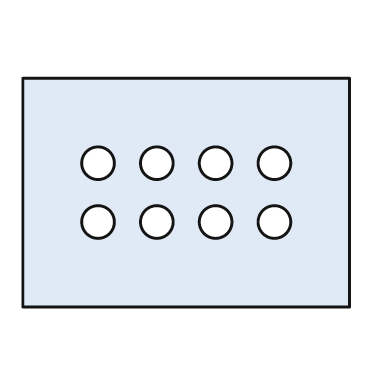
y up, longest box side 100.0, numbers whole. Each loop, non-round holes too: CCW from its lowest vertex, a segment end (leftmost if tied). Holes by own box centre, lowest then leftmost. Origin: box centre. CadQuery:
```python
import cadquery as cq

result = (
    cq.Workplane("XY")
    .moveTo(-50.0, -35.0)
    .lineTo(50.0, -35.0)
    .lineTo(50.0, 35.0)
    .lineTo(-50.0, 35.0)
    .close()
    .moveTo(-27.0, -9.0)
    .circle(5.0)
    .moveTo(-9.0, -9.0)
    .circle(5.0)
    .moveTo(9.0, -9.0)
    .circle(5.0)
    .moveTo(27.0, -9.0)
    .circle(5.0)
    .moveTo(-27.0, 9.0)
    .circle(5.0)
    .moveTo(-9.0, 9.0)
    .circle(5.0)
    .moveTo(9.0, 9.0)
    .circle(5.0)
    .moveTo(27.0, 9.0)
    .circle(5.0)
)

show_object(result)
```